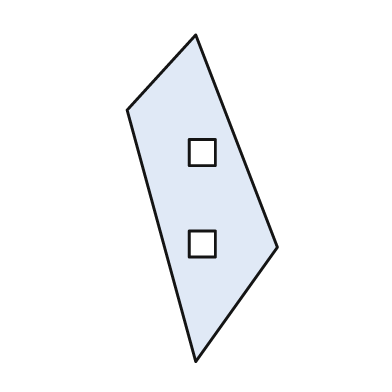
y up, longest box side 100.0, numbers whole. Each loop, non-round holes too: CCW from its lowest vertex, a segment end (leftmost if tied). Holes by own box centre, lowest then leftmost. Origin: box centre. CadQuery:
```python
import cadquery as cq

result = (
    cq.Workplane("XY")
    .moveTo(-2.0, -50.0)
    .lineTo(23.0, -15.0)
    .lineTo(-2.0, 50.0)
    .lineTo(-23.0, 27.0)
    .close()
    .moveTo(-4.0, -18.0)
    .lineTo(4.0, -18.0)
    .lineTo(4.0, -10.0)
    .lineTo(-4.0, -10.0)
    .close()
    .moveTo(-4.0, 10.0)
    .lineTo(4.0, 10.0)
    .lineTo(4.0, 18.0)
    .lineTo(-4.0, 18.0)
    .close()
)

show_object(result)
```